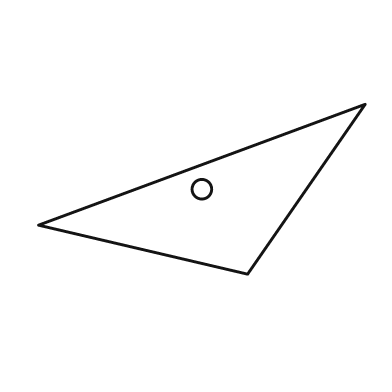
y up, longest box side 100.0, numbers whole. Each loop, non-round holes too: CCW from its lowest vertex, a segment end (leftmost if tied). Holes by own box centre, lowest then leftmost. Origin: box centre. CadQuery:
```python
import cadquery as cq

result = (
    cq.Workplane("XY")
    .moveTo(14.0, -26.0)
    .lineTo(50.0, 26.0)
    .lineTo(-50.0, -11.0)
    .close()
    .moveTo(0.0, 0.0)
    .circle(3.0)
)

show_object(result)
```